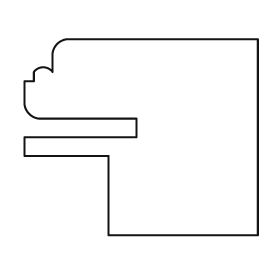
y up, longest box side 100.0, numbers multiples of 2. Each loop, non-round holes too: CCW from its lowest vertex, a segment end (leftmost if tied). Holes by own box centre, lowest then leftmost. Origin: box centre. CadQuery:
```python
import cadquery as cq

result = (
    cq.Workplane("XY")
    .moveTo(-14.0, -42.0)
    .lineTo(50.0, -42.0)
    .lineTo(50.0, 42.0)
    .lineTo(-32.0, 42.0)
    .threePointArc((-36.0, 40.0), (-38.0, 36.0))
    .lineTo(-38.0, 28.0)
    .threePointArc((-42.0, 30.0), (-46.0, 28.0))
    .lineTo(-46.0, 24.0)
    .lineTo(-50.0, 24.0)
    .lineTo(-50.0, 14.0)
    .threePointArc((-48.0, 10.0), (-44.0, 8.0))
    .lineTo(-2.0, 8.0)
    .lineTo(-2.0, 0.0)
    .lineTo(-50.0, 0.0)
    .lineTo(-50.0, -8.0)
    .lineTo(-14.0, -8.0)
    .close()
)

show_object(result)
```